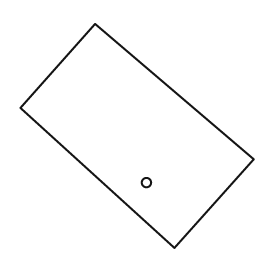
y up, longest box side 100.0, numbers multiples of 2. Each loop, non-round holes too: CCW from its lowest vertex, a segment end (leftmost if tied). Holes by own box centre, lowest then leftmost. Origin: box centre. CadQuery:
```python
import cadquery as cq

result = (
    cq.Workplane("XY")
    .moveTo(16.0, -48.0)
    .lineTo(50.0, -10.0)
    .lineTo(-18.0, 48.0)
    .lineTo(-50.0, 12.0)
    .close()
    .moveTo(4.0, -20.0)
    .circle(2.0)
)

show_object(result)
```